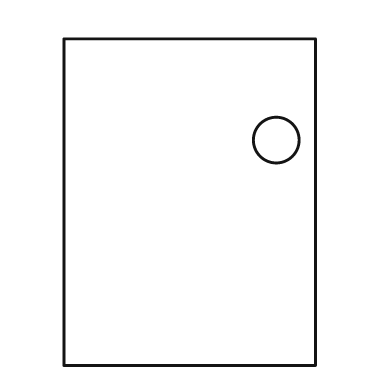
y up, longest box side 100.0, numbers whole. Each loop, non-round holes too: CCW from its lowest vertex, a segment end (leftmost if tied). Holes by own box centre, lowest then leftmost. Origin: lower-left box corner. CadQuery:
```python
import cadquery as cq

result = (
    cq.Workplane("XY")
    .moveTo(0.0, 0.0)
    .lineTo(77.0, 0.0)
    .lineTo(77.0, 100.0)
    .lineTo(0.0, 100.0)
    .close()
    .moveTo(65.0, 69.0)
    .circle(7.0)
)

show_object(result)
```